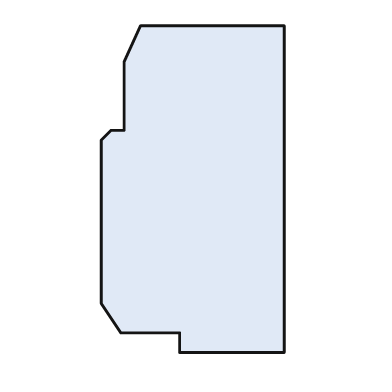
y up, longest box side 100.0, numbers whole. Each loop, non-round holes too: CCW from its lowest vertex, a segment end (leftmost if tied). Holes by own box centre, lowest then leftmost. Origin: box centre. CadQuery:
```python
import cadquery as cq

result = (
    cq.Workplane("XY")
    .moveTo(-4.0, -50.0)
    .lineTo(28.0, -50.0)
    .lineTo(28.0, 50.0)
    .lineTo(-16.0, 50.0)
    .lineTo(-21.0, 39.0)
    .lineTo(-21.0, 18.0)
    .lineTo(-25.0, 18.0)
    .lineTo(-28.0, 15.0)
    .lineTo(-28.0, -35.0)
    .lineTo(-22.0, -44.0)
    .lineTo(-4.0, -44.0)
    .close()
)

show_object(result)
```